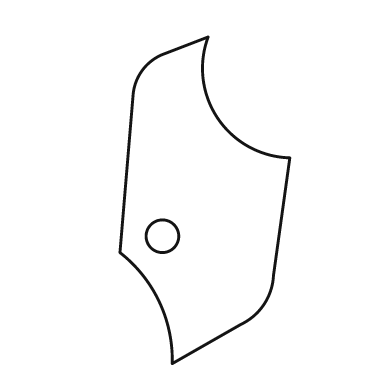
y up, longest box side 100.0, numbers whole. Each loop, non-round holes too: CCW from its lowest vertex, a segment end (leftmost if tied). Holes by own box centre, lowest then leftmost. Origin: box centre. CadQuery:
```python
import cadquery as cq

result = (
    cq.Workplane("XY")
    .moveTo(-10.0, -50.0)
    .lineTo(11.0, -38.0)
    .threePointArc((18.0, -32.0), (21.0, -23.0))
    .lineTo(26.0, 13.0)
    .threePointArc((4.0, 25.0), (1.0, 50.0))
    .lineTo(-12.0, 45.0)
    .threePointArc((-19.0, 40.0), (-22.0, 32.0))
    .lineTo(-26.0, -16.0)
    .threePointArc((-14.0, -31.0), (-10.0, -50.0))
    .close()
    .moveTo(-13.0, -11.0)
    .circle(5.0)
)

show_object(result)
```